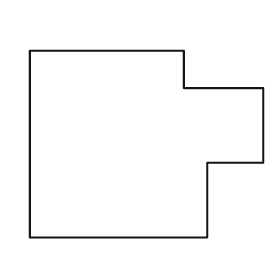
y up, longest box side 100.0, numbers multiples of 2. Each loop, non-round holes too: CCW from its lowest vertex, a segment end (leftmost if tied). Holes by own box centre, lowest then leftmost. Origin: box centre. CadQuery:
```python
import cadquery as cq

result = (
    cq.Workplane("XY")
    .moveTo(-50.0, -40.0)
    .lineTo(26.0, -40.0)
    .lineTo(26.0, -8.0)
    .lineTo(50.0, -8.0)
    .lineTo(50.0, 24.0)
    .lineTo(16.0, 24.0)
    .lineTo(16.0, 40.0)
    .lineTo(-50.0, 40.0)
    .close()
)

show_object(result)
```